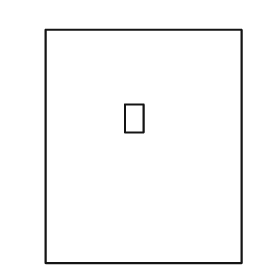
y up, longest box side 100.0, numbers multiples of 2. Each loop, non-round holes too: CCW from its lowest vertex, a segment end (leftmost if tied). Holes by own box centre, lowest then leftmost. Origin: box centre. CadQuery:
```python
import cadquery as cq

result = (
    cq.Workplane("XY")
    .moveTo(-42.0, -50.0)
    .lineTo(42.0, -50.0)
    .lineTo(42.0, 50.0)
    .lineTo(-42.0, 50.0)
    .close()
    .moveTo(-8.0, 6.0)
    .lineTo(0.0, 6.0)
    .lineTo(0.0, 18.0)
    .lineTo(-8.0, 18.0)
    .close()
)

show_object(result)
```